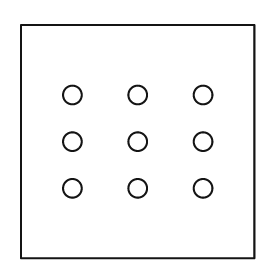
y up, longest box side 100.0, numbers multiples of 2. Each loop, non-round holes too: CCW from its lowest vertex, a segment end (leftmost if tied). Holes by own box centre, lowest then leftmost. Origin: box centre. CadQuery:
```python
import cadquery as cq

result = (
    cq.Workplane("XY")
    .moveTo(-50.0, -50.0)
    .lineTo(50.0, -50.0)
    .lineTo(50.0, 50.0)
    .lineTo(-50.0, 50.0)
    .close()
    .moveTo(-28.0, -20.0)
    .circle(4.0)
    .moveTo(0.0, -20.0)
    .circle(4.0)
    .moveTo(28.0, -20.0)
    .circle(4.0)
    .moveTo(-28.0, 0.0)
    .circle(4.0)
    .moveTo(0.0, 0.0)
    .circle(4.0)
    .moveTo(28.0, 0.0)
    .circle(4.0)
    .moveTo(-28.0, 20.0)
    .circle(4.0)
    .moveTo(0.0, 20.0)
    .circle(4.0)
    .moveTo(28.0, 20.0)
    .circle(4.0)
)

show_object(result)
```